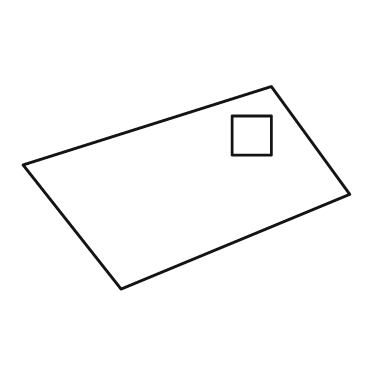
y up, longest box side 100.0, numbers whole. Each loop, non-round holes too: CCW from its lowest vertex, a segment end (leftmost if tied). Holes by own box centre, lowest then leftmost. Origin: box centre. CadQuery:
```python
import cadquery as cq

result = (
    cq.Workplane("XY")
    .moveTo(-20.0, -31.0)
    .lineTo(50.0, -2.0)
    .lineTo(26.0, 31.0)
    .lineTo(-50.0, 7.0)
    .close()
    .moveTo(14.0, 10.0)
    .lineTo(26.0, 10.0)
    .lineTo(26.0, 22.0)
    .lineTo(14.0, 22.0)
    .close()
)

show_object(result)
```